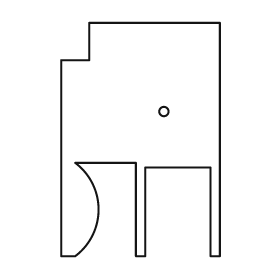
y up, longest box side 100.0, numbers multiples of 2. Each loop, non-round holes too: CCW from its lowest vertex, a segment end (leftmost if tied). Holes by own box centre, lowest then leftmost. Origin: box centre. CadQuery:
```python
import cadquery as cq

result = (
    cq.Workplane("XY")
    .moveTo(-34.0, -50.0)
    .lineTo(-28.0, -50.0)
    .threePointArc((-18.0, -30.0), (-28.0, -10.0))
    .lineTo(-2.0, -10.0)
    .lineTo(-2.0, -50.0)
    .lineTo(2.0, -50.0)
    .lineTo(2.0, -12.0)
    .lineTo(30.0, -12.0)
    .lineTo(30.0, -50.0)
    .lineTo(34.0, -50.0)
    .lineTo(34.0, 50.0)
    .lineTo(-22.0, 50.0)
    .lineTo(-22.0, 34.0)
    .lineTo(-34.0, 34.0)
    .close()
    .moveTo(10.0, 12.0)
    .circle(2.0)
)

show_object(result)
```